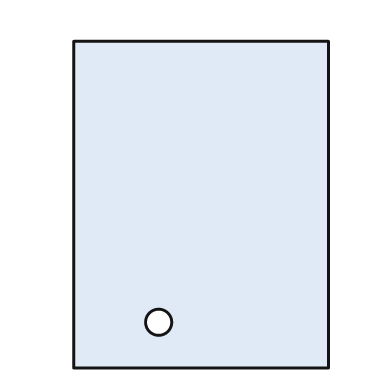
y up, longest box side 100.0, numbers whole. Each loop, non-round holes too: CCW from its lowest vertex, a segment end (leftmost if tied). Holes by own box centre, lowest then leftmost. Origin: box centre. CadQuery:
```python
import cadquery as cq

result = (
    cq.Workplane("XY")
    .moveTo(-39.0, -50.0)
    .lineTo(39.0, -50.0)
    .lineTo(39.0, 50.0)
    .lineTo(-39.0, 50.0)
    .close()
    .moveTo(-13.0, -36.0)
    .circle(4.0)
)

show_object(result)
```